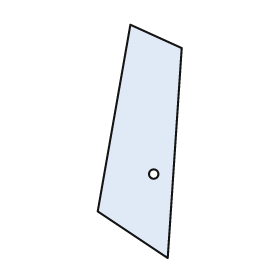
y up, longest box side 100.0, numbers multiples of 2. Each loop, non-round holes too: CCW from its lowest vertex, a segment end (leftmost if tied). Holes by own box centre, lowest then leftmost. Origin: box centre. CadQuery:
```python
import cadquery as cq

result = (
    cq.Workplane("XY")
    .moveTo(12.0, -50.0)
    .lineTo(18.0, 40.0)
    .lineTo(-4.0, 50.0)
    .lineTo(-18.0, -30.0)
    .close()
    .moveTo(6.0, -14.0)
    .circle(2.0)
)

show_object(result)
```